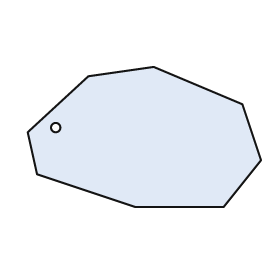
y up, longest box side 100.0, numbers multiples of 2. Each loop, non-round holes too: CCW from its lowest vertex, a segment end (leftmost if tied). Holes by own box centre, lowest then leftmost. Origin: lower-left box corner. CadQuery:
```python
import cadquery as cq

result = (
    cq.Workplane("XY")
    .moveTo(46.0, 0.0)
    .lineTo(84.0, 0.0)
    .lineTo(100.0, 20.0)
    .lineTo(92.0, 44.0)
    .lineTo(54.0, 60.0)
    .lineTo(26.0, 56.0)
    .lineTo(0.0, 32.0)
    .lineTo(4.0, 14.0)
    .close()
    .moveTo(12.0, 34.0)
    .circle(2.0)
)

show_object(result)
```